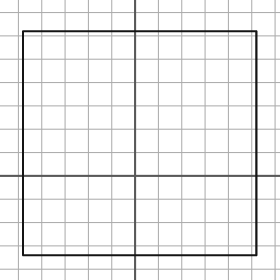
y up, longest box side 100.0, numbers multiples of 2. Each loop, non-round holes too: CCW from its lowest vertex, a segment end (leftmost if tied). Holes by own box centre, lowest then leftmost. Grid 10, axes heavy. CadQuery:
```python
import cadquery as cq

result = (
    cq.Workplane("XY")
    .moveTo(-48.0, -34.0)
    .lineTo(52.0, -34.0)
    .lineTo(52.0, 62.0)
    .lineTo(-48.0, 62.0)
    .close()
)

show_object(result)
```